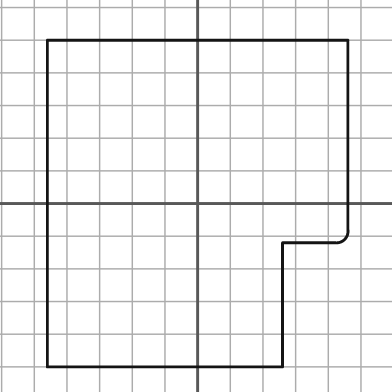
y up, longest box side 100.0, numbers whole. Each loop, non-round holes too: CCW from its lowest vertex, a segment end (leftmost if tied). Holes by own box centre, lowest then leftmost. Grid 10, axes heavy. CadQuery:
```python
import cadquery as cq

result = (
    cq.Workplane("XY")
    .moveTo(-46.0, -50.0)
    .lineTo(26.0, -50.0)
    .lineTo(26.0, -12.0)
    .lineTo(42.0, -12.0)
    .threePointArc((45.0, -11.0), (46.0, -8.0))
    .lineTo(46.0, 50.0)
    .lineTo(-46.0, 50.0)
    .close()
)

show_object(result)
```